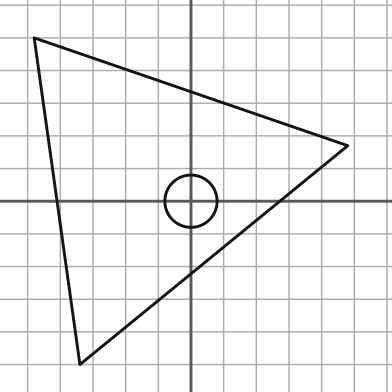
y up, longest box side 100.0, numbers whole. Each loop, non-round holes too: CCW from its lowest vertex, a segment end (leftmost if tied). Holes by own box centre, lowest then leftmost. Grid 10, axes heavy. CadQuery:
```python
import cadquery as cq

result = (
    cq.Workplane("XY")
    .moveTo(-34.0, -50.0)
    .lineTo(48.0, 17.0)
    .lineTo(-48.0, 50.0)
    .close()
    .moveTo(0.0, 0.0)
    .circle(8.0)
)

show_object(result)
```